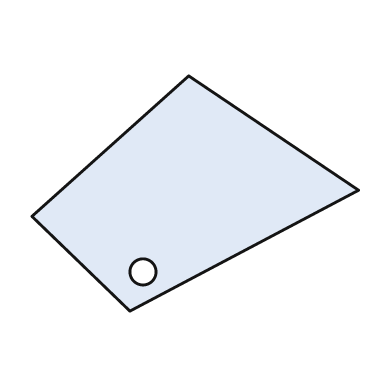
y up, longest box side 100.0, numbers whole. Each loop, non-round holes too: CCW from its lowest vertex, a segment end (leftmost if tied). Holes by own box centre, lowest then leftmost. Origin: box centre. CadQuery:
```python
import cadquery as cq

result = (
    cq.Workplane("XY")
    .moveTo(-20.0, -36.0)
    .lineTo(50.0, 1.0)
    .lineTo(-2.0, 36.0)
    .lineTo(-50.0, -7.0)
    .close()
    .moveTo(-16.0, -24.0)
    .circle(4.0)
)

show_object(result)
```